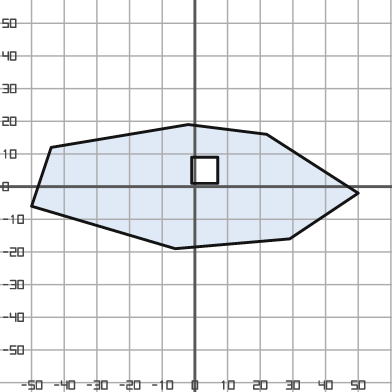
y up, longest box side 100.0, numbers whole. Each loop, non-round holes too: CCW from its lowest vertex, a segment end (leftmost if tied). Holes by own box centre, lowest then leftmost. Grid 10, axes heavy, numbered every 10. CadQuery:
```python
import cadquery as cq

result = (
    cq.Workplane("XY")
    .moveTo(-6.0, -19.0)
    .lineTo(29.0, -16.0)
    .lineTo(50.0, -2.0)
    .lineTo(22.0, 16.0)
    .lineTo(-2.0, 19.0)
    .lineTo(-44.0, 12.0)
    .lineTo(-50.0, -6.0)
    .close()
    .moveTo(-1.0, 1.0)
    .lineTo(7.0, 1.0)
    .lineTo(7.0, 9.0)
    .lineTo(-1.0, 9.0)
    .close()
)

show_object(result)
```